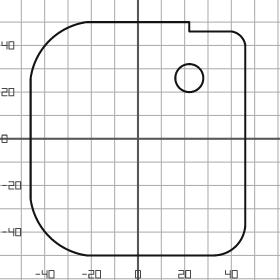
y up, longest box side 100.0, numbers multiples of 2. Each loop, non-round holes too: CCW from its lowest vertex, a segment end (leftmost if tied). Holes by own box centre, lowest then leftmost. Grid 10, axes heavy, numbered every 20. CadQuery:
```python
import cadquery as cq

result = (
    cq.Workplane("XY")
    .moveTo(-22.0, -50.0)
    .lineTo(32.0, -50.0)
    .threePointArc((42.0, -46.0), (46.0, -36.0))
    .lineTo(46.0, 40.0)
    .threePointArc((44.0, 44.0), (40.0, 46.0))
    .lineTo(22.0, 46.0)
    .lineTo(22.0, 50.0)
    .lineTo(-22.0, 50.0)
    .threePointArc((-38.0, 42.0), (-46.0, 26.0))
    .lineTo(-46.0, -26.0)
    .threePointArc((-38.0, -42.0), (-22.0, -50.0))
    .close()
    .moveTo(22.0, 26.0)
    .circle(6.0)
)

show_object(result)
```